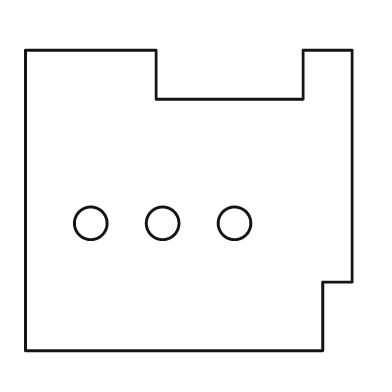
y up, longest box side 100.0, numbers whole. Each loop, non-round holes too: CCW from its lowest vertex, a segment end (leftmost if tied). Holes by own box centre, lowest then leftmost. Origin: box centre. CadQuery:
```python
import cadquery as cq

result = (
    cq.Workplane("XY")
    .moveTo(-50.0, -46.0)
    .lineTo(41.0, -46.0)
    .lineTo(41.0, -25.0)
    .lineTo(50.0, -25.0)
    .lineTo(50.0, 46.0)
    .lineTo(35.0, 46.0)
    .lineTo(35.0, 31.0)
    .lineTo(-10.0, 31.0)
    .lineTo(-10.0, 46.0)
    .lineTo(-50.0, 46.0)
    .close()
    .moveTo(-30.0, -7.0)
    .circle(5.0)
    .moveTo(-8.0, -7.0)
    .circle(5.0)
    .moveTo(14.0, -7.0)
    .circle(5.0)
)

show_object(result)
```